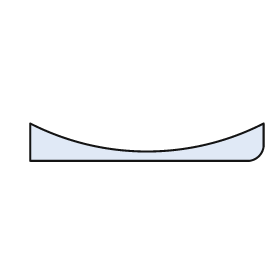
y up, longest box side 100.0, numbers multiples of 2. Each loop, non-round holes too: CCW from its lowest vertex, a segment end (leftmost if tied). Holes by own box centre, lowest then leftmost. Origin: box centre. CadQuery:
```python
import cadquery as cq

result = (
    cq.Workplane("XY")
    .moveTo(-50.0, -8.0)
    .lineTo(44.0, -8.0)
    .threePointArc((48.0, -6.0), (50.0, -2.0))
    .lineTo(50.0, 8.0)
    .threePointArc((0.0, -4.0), (-50.0, 8.0))
    .close()
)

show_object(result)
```